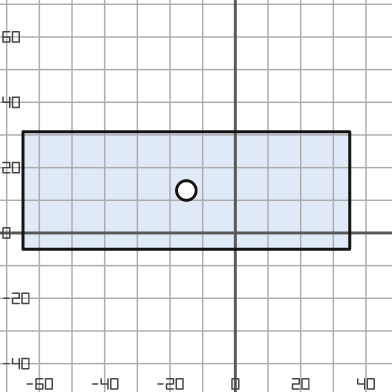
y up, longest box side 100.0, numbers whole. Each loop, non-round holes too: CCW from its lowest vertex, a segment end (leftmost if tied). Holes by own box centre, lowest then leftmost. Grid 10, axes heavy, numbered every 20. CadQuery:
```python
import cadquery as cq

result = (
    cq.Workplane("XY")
    .moveTo(-65.0, -5.0)
    .lineTo(35.0, -5.0)
    .lineTo(35.0, 31.0)
    .lineTo(-65.0, 31.0)
    .close()
    .moveTo(-15.0, 13.0)
    .circle(3.0)
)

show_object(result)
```